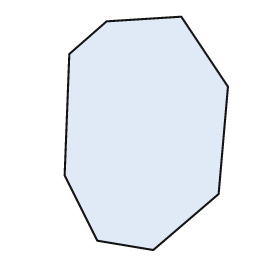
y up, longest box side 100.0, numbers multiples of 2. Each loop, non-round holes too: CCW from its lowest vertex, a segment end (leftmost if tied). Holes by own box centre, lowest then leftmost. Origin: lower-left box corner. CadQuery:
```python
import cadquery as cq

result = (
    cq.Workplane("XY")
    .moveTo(38.0, 0.0)
    .lineTo(66.0, 24.0)
    .lineTo(70.0, 70.0)
    .lineTo(50.0, 100.0)
    .lineTo(18.0, 98.0)
    .lineTo(2.0, 84.0)
    .lineTo(0.0, 32.0)
    .lineTo(14.0, 4.0)
    .close()
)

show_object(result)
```